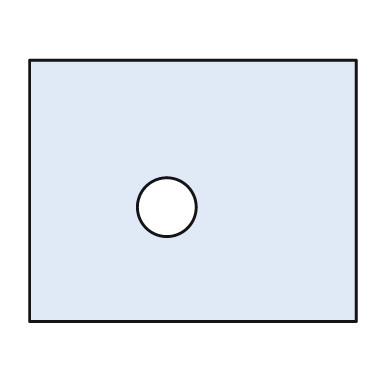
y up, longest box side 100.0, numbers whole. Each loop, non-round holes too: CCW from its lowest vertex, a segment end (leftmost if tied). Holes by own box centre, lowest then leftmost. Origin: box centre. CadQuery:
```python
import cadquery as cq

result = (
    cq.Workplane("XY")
    .moveTo(-50.0, -40.0)
    .lineTo(50.0, -40.0)
    .lineTo(50.0, 40.0)
    .lineTo(-50.0, 40.0)
    .close()
    .moveTo(-8.0, -5.0)
    .circle(9.0)
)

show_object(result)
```